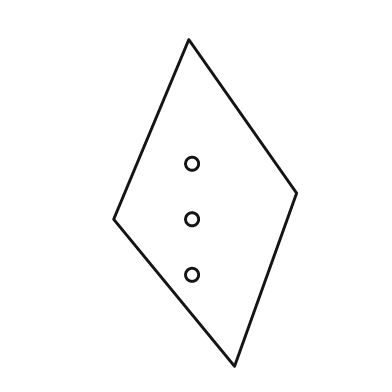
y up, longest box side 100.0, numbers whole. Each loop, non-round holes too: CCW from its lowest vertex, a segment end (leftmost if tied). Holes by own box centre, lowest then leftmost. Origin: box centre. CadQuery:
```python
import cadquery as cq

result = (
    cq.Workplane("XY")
    .moveTo(9.0, -50.0)
    .lineTo(28.0, 3.0)
    .lineTo(-5.0, 50.0)
    .lineTo(-28.0, -5.0)
    .close()
    .moveTo(-4.0, -22.0)
    .circle(2.0)
    .moveTo(-4.0, -5.0)
    .circle(2.0)
    .moveTo(-4.0, 12.0)
    .circle(2.0)
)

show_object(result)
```